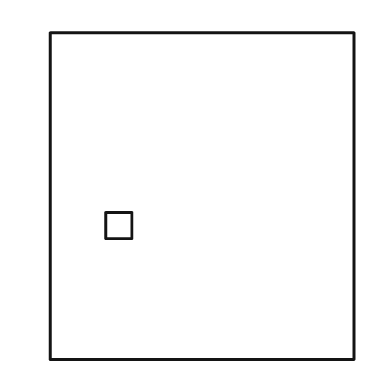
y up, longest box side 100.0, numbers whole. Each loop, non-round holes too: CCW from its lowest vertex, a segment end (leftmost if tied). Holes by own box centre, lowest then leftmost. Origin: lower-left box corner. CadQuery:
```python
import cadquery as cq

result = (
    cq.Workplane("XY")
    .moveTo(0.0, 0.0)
    .lineTo(93.0, 0.0)
    .lineTo(93.0, 100.0)
    .lineTo(0.0, 100.0)
    .close()
    .moveTo(17.0, 37.0)
    .lineTo(25.0, 37.0)
    .lineTo(25.0, 45.0)
    .lineTo(17.0, 45.0)
    .close()
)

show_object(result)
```